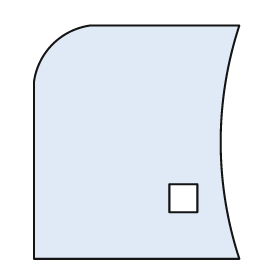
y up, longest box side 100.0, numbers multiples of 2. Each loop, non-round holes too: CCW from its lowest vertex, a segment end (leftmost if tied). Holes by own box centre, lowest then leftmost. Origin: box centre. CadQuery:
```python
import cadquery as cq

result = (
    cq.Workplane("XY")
    .moveTo(-44.0, -50.0)
    .lineTo(44.0, -50.0)
    .threePointArc((36.0, 0.0), (44.0, 50.0))
    .lineTo(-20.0, 50.0)
    .threePointArc((-36.0, 42.0), (-44.0, 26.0))
    .close()
    .moveTo(14.0, -30.0)
    .lineTo(26.0, -30.0)
    .lineTo(26.0, -18.0)
    .lineTo(14.0, -18.0)
    .close()
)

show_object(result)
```